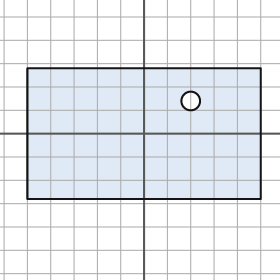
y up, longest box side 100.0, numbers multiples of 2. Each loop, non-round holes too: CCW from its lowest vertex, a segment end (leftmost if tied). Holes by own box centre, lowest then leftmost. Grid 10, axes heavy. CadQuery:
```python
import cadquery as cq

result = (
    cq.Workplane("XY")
    .moveTo(-50.0, -28.0)
    .lineTo(50.0, -28.0)
    .lineTo(50.0, 28.0)
    .lineTo(-50.0, 28.0)
    .close()
    .moveTo(20.0, 14.0)
    .circle(4.0)
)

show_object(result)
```